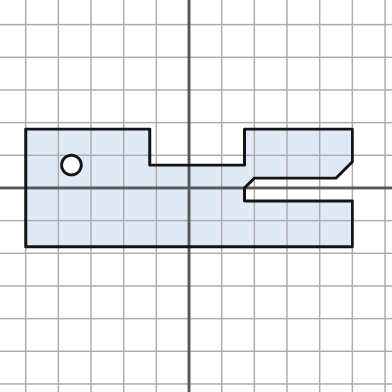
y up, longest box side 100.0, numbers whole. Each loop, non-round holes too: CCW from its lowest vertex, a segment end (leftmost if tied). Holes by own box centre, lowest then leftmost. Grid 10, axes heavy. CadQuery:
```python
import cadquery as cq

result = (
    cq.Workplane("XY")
    .moveTo(-50.0, -18.0)
    .lineTo(50.0, -18.0)
    .lineTo(50.0, -4.0)
    .lineTo(17.0, -4.0)
    .lineTo(17.0, 0.0)
    .lineTo(20.0, 3.0)
    .lineTo(45.0, 3.0)
    .lineTo(50.0, 8.0)
    .lineTo(50.0, 18.0)
    .lineTo(17.0, 18.0)
    .lineTo(17.0, 7.0)
    .lineTo(-12.0, 7.0)
    .lineTo(-12.0, 18.0)
    .lineTo(-50.0, 18.0)
    .close()
    .moveTo(-36.0, 7.0)
    .circle(3.0)
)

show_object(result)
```